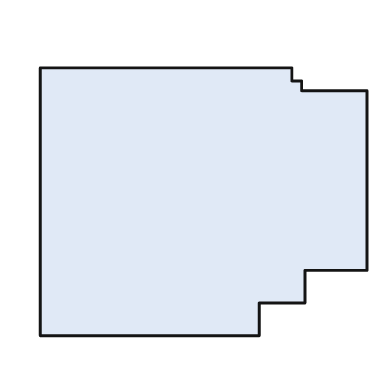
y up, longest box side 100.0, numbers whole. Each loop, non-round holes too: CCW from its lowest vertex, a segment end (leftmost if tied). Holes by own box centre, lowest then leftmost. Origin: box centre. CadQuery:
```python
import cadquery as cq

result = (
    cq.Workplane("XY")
    .moveTo(-50.0, -41.0)
    .lineTo(17.0, -41.0)
    .lineTo(17.0, -31.0)
    .lineTo(31.0, -31.0)
    .lineTo(31.0, -21.0)
    .lineTo(50.0, -21.0)
    .lineTo(50.0, 34.0)
    .lineTo(30.0, 34.0)
    .lineTo(30.0, 37.0)
    .lineTo(27.0, 37.0)
    .lineTo(27.0, 41.0)
    .lineTo(-50.0, 41.0)
    .close()
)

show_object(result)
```